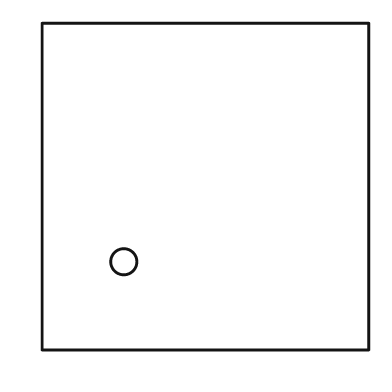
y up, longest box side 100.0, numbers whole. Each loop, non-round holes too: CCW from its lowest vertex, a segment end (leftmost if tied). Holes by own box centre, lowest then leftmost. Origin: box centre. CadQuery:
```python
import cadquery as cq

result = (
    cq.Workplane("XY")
    .moveTo(-50.0, -50.0)
    .lineTo(50.0, -50.0)
    .lineTo(50.0, 50.0)
    .lineTo(-50.0, 50.0)
    .close()
    .moveTo(-25.0, -23.0)
    .circle(4.0)
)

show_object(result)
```